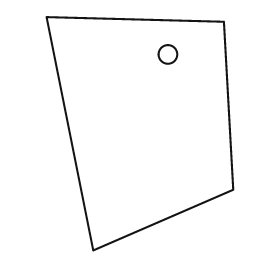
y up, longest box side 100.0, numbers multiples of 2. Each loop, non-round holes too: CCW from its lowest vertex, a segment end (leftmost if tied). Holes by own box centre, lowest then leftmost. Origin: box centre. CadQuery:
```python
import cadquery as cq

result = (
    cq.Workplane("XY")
    .moveTo(-20.0, -50.0)
    .lineTo(40.0, -24.0)
    .lineTo(36.0, 48.0)
    .lineTo(-40.0, 50.0)
    .close()
    .moveTo(12.0, 34.0)
    .circle(4.0)
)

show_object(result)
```